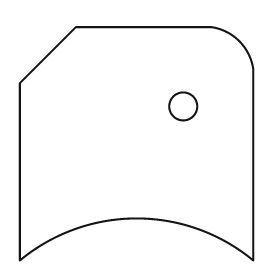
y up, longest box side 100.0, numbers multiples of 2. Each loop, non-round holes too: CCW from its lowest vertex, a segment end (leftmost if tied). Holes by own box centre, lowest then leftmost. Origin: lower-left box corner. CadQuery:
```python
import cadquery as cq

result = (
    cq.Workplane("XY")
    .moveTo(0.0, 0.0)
    .threePointArc((50.0, 18.0), (100.0, 0.0))
    .lineTo(100.0, 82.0)
    .threePointArc((94.0, 94.0), (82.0, 100.0))
    .lineTo(24.0, 100.0)
    .lineTo(0.0, 76.0)
    .close()
    .moveTo(70.0, 66.0)
    .circle(6.0)
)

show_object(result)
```